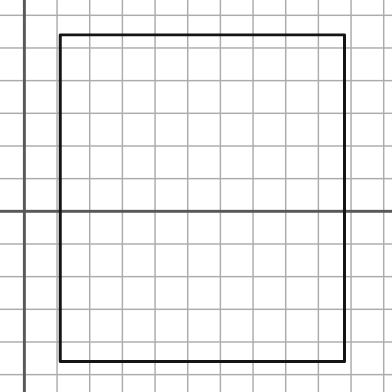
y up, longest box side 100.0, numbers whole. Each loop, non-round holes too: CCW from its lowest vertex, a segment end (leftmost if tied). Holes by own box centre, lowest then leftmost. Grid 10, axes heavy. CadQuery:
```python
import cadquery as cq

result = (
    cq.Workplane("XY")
    .moveTo(11.0, -46.0)
    .lineTo(98.0, -46.0)
    .lineTo(98.0, 54.0)
    .lineTo(11.0, 54.0)
    .close()
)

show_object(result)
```